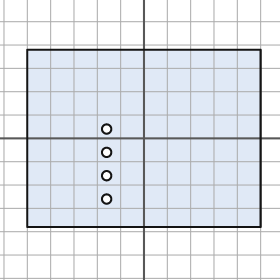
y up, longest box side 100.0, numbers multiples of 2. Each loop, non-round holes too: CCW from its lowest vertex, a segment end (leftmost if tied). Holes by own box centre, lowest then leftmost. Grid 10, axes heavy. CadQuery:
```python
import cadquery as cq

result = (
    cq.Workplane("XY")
    .moveTo(-50.0, -38.0)
    .lineTo(50.0, -38.0)
    .lineTo(50.0, 38.0)
    .lineTo(-50.0, 38.0)
    .close()
    .moveTo(-16.0, -26.0)
    .circle(2.0)
    .moveTo(-16.0, -16.0)
    .circle(2.0)
    .moveTo(-16.0, -6.0)
    .circle(2.0)
    .moveTo(-16.0, 4.0)
    .circle(2.0)
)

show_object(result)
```